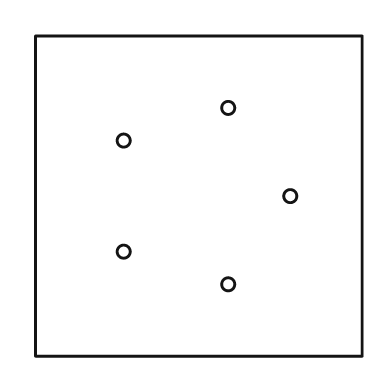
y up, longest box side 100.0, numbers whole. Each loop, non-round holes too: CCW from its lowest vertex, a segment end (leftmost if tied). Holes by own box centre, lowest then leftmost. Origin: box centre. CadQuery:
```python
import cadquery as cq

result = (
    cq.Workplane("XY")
    .moveTo(-50.0, -49.0)
    .lineTo(50.0, -49.0)
    .lineTo(50.0, 49.0)
    .lineTo(-50.0, 49.0)
    .close()
    .moveTo(9.0, -27.0)
    .circle(2.0)
    .moveTo(-23.0, -17.0)
    .circle(2.0)
    .moveTo(28.0, 0.0)
    .circle(2.0)
    .moveTo(-23.0, 17.0)
    .circle(2.0)
    .moveTo(9.0, 27.0)
    .circle(2.0)
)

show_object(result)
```